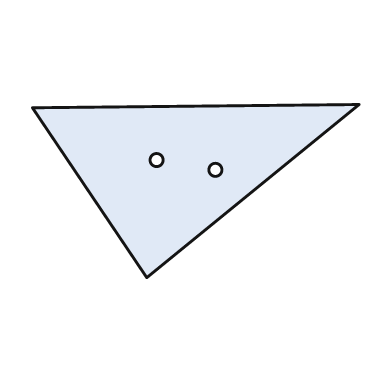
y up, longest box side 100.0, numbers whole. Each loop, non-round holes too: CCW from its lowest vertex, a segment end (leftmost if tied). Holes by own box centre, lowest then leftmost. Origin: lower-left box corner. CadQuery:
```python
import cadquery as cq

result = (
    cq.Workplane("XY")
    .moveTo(35.0, 0.0)
    .lineTo(100.0, 53.0)
    .lineTo(0.0, 52.0)
    .close()
    .moveTo(56.0, 33.0)
    .circle(2.0)
    .moveTo(38.0, 36.0)
    .circle(2.0)
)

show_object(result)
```